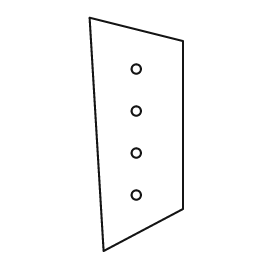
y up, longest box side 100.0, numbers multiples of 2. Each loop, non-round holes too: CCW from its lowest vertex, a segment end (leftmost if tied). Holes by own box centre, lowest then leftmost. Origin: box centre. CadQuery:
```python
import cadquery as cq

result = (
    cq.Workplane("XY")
    .moveTo(-14.0, -50.0)
    .lineTo(20.0, -32.0)
    .lineTo(20.0, 40.0)
    .lineTo(-20.0, 50.0)
    .close()
    .moveTo(0.0, -26.0)
    .circle(2.0)
    .moveTo(0.0, -8.0)
    .circle(2.0)
    .moveTo(0.0, 10.0)
    .circle(2.0)
    .moveTo(0.0, 28.0)
    .circle(2.0)
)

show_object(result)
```